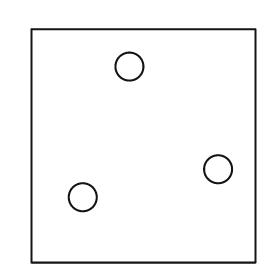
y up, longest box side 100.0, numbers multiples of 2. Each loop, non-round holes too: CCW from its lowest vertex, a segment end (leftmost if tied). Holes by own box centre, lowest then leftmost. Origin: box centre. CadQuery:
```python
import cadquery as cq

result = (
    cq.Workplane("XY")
    .moveTo(-48.0, -50.0)
    .lineTo(48.0, -50.0)
    .lineTo(48.0, 50.0)
    .lineTo(-48.0, 50.0)
    .close()
    .moveTo(-26.0, -22.0)
    .circle(6.0)
    .moveTo(32.0, -10.0)
    .circle(6.0)
    .moveTo(-6.0, 34.0)
    .circle(6.0)
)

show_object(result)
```